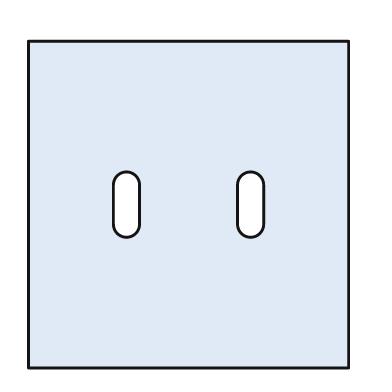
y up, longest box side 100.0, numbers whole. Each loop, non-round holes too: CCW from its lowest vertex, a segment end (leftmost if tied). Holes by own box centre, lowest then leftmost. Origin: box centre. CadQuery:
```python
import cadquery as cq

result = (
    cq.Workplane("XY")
    .moveTo(-49.0, -50.0)
    .lineTo(49.0, -50.0)
    .lineTo(49.0, 50.0)
    .lineTo(-49.0, 50.0)
    .close()
    .moveTo(-23.0, -6.0)
    .threePointArc((-19.0, -10.0), (-15.0, -6.0))
    .lineTo(-15.0, 6.0)
    .threePointArc((-19.0, 10.0), (-23.0, 6.0))
    .close()
    .moveTo(15.0, -6.0)
    .threePointArc((19.0, -10.0), (23.0, -6.0))
    .lineTo(23.0, 6.0)
    .threePointArc((19.0, 10.0), (15.0, 6.0))
    .close()
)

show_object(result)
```